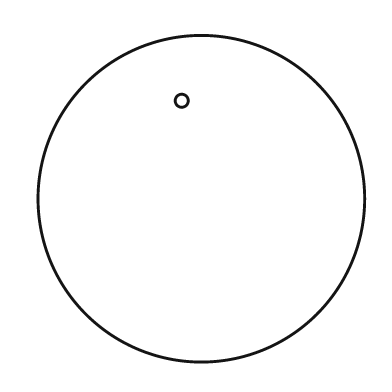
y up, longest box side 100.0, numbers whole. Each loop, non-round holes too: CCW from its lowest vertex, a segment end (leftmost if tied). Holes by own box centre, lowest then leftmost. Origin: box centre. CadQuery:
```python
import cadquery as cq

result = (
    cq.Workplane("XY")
    .moveTo(0.0, 0.0)
    .circle(50.0)
    .moveTo(-6.0, 30.0)
    .circle(2.0)
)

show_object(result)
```